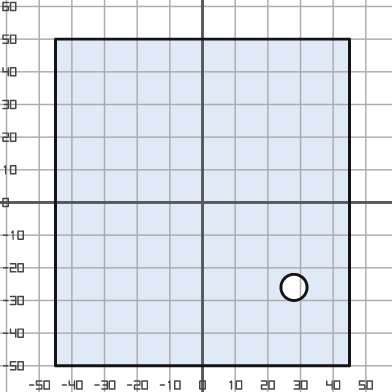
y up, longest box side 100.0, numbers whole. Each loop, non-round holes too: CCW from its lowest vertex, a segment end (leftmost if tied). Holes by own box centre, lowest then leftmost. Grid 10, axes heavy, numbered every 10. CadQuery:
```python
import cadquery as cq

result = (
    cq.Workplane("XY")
    .moveTo(-45.0, -50.0)
    .lineTo(45.0, -50.0)
    .lineTo(45.0, 50.0)
    .lineTo(-45.0, 50.0)
    .close()
    .moveTo(28.0, -26.0)
    .circle(4.0)
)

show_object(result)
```